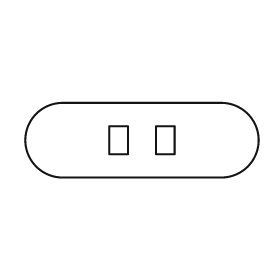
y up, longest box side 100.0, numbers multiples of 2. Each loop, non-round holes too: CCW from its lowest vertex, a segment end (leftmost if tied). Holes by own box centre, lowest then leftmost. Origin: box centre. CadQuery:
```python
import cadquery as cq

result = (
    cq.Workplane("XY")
    .moveTo(-34.0, -16.0)
    .lineTo(34.0, -16.0)
    .threePointArc((50.0, 0.0), (34.0, 16.0))
    .lineTo(-34.0, 16.0)
    .threePointArc((-50.0, 0.0), (-34.0, -16.0))
    .close()
    .moveTo(-14.0, -6.0)
    .lineTo(-6.0, -6.0)
    .lineTo(-6.0, 6.0)
    .lineTo(-14.0, 6.0)
    .close()
    .moveTo(6.0, -6.0)
    .lineTo(14.0, -6.0)
    .lineTo(14.0, 6.0)
    .lineTo(6.0, 6.0)
    .close()
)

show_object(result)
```